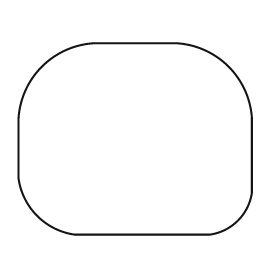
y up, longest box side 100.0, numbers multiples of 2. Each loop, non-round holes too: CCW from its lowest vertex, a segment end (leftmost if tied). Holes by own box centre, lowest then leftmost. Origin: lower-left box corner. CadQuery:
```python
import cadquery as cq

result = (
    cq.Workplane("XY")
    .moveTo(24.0, 0.0)
    .lineTo(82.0, 0.0)
    .threePointArc((94.0, 6.0), (100.0, 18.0))
    .lineTo(100.0, 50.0)
    .threePointArc((90.0, 72.0), (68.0, 82.0))
    .lineTo(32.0, 82.0)
    .threePointArc((10.0, 72.0), (0.0, 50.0))
    .lineTo(0.0, 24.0)
    .threePointArc((8.0, 8.0), (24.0, 0.0))
    .close()
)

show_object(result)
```